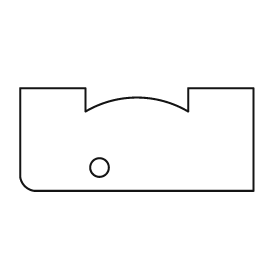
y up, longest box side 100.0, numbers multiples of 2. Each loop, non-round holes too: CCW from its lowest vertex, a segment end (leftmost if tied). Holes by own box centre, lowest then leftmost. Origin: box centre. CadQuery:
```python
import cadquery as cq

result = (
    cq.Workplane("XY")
    .moveTo(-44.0, -22.0)
    .lineTo(50.0, -22.0)
    .lineTo(50.0, 22.0)
    .lineTo(22.0, 22.0)
    .lineTo(22.0, 12.0)
    .threePointArc((0.0, 18.0), (-22.0, 12.0))
    .lineTo(-22.0, 22.0)
    .lineTo(-50.0, 22.0)
    .lineTo(-50.0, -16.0)
    .threePointArc((-48.0, -20.0), (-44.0, -22.0))
    .close()
    .moveTo(-16.0, -12.0)
    .circle(4.0)
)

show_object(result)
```